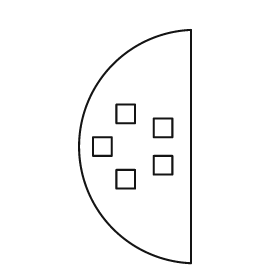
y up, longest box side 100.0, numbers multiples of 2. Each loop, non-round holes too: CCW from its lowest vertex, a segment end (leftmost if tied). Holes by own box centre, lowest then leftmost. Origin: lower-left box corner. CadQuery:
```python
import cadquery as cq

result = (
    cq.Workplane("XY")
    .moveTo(48.0, 0.0)
    .lineTo(48.0, 100.0)
    .threePointArc((0.0, 50.0), (48.0, 0.0))
    .close()
    .moveTo(16.0, 32.0)
    .lineTo(24.0, 32.0)
    .lineTo(24.0, 40.0)
    .lineTo(16.0, 40.0)
    .close()
    .moveTo(32.0, 38.0)
    .lineTo(40.0, 38.0)
    .lineTo(40.0, 46.0)
    .lineTo(32.0, 46.0)
    .close()
    .moveTo(6.0, 46.0)
    .lineTo(14.0, 46.0)
    .lineTo(14.0, 54.0)
    .lineTo(6.0, 54.0)
    .close()
    .moveTo(32.0, 54.0)
    .lineTo(40.0, 54.0)
    .lineTo(40.0, 62.0)
    .lineTo(32.0, 62.0)
    .close()
    .moveTo(16.0, 60.0)
    .lineTo(24.0, 60.0)
    .lineTo(24.0, 68.0)
    .lineTo(16.0, 68.0)
    .close()
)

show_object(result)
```